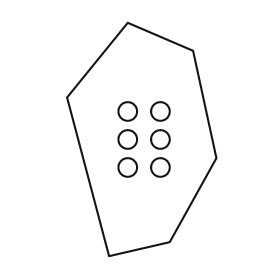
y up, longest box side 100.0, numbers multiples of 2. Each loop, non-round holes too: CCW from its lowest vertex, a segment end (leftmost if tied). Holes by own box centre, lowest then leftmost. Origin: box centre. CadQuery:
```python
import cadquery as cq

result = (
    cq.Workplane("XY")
    .moveTo(-14.0, -50.0)
    .lineTo(12.0, -44.0)
    .lineTo(32.0, -8.0)
    .lineTo(22.0, 38.0)
    .lineTo(-6.0, 50.0)
    .lineTo(-32.0, 18.0)
    .close()
    .moveTo(-6.0, -12.0)
    .circle(4.0)
    .moveTo(8.0, -12.0)
    .circle(4.0)
    .moveTo(-6.0, 0.0)
    .circle(4.0)
    .moveTo(8.0, 0.0)
    .circle(4.0)
    .moveTo(-6.0, 12.0)
    .circle(4.0)
    .moveTo(8.0, 12.0)
    .circle(4.0)
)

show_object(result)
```